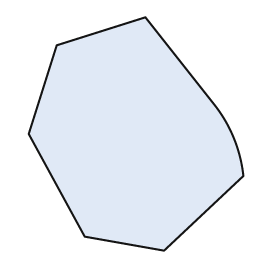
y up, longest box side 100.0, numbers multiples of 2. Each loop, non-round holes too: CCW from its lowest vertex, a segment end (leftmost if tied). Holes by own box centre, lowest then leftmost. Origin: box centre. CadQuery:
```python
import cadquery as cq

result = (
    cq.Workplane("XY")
    .moveTo(12.0, -50.0)
    .lineTo(46.0, -18.0)
    .threePointArc((42.0, -2.0), (34.0, 12.0))
    .lineTo(4.0, 50.0)
    .lineTo(-34.0, 38.0)
    .lineTo(-46.0, 0.0)
    .lineTo(-22.0, -44.0)
    .close()
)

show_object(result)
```